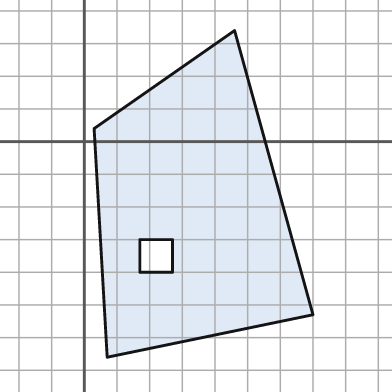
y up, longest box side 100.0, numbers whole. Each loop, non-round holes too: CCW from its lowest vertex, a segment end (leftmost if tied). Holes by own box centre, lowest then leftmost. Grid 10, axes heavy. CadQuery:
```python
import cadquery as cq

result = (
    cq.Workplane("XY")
    .moveTo(7.0, -66.0)
    .lineTo(70.0, -53.0)
    .lineTo(46.0, 34.0)
    .lineTo(3.0, 4.0)
    .close()
    .moveTo(17.0, -40.0)
    .lineTo(27.0, -40.0)
    .lineTo(27.0, -30.0)
    .lineTo(17.0, -30.0)
    .close()
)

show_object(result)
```